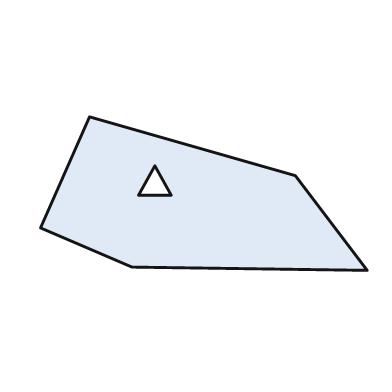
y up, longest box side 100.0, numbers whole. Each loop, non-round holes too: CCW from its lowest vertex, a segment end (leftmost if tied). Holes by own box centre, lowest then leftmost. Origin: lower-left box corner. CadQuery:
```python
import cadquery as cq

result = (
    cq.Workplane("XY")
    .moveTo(100.0, 0.0)
    .lineTo(78.0, 29.0)
    .lineTo(15.0, 47.0)
    .lineTo(0.0, 13.0)
    .lineTo(28.0, 1.0)
    .close()
    .moveTo(30.0, 23.0)
    .lineTo(40.0, 23.0)
    .lineTo(35.0, 32.0)
    .close()
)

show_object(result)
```